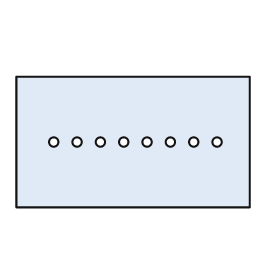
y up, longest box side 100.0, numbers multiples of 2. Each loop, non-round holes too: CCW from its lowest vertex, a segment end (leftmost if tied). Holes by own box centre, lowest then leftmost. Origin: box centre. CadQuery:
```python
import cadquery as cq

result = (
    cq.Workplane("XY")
    .moveTo(-50.0, -28.0)
    .lineTo(50.0, -28.0)
    .lineTo(50.0, 28.0)
    .lineTo(-50.0, 28.0)
    .close()
    .moveTo(-34.0, 0.0)
    .circle(2.0)
    .moveTo(-24.0, 0.0)
    .circle(2.0)
    .moveTo(-14.0, 0.0)
    .circle(2.0)
    .moveTo(-4.0, 0.0)
    .circle(2.0)
    .moveTo(6.0, 0.0)
    .circle(2.0)
    .moveTo(16.0, 0.0)
    .circle(2.0)
    .moveTo(26.0, 0.0)
    .circle(2.0)
    .moveTo(36.0, 0.0)
    .circle(2.0)
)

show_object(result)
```